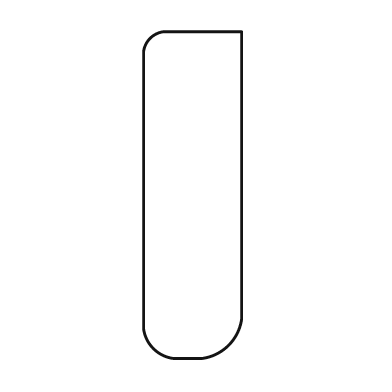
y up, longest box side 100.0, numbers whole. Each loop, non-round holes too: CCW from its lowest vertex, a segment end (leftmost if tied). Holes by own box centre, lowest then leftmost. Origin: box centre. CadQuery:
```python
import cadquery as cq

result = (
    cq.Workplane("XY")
    .moveTo(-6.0, -50.0)
    .lineTo(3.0, -50.0)
    .threePointArc((11.0, -46.0), (15.0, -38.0))
    .lineTo(15.0, 50.0)
    .lineTo(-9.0, 50.0)
    .threePointArc((-13.0, 48.0), (-15.0, 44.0))
    .lineTo(-15.0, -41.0)
    .threePointArc((-12.0, -47.0), (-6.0, -50.0))
    .close()
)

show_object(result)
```